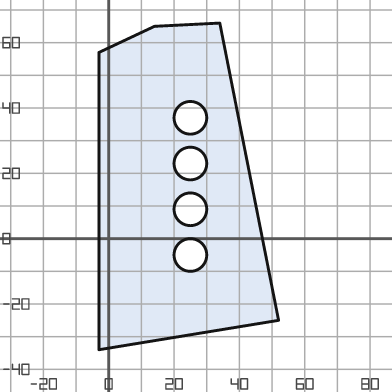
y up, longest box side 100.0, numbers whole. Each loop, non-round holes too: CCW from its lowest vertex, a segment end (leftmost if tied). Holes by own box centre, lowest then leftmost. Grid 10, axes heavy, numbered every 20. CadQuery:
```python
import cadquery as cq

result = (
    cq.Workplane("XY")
    .moveTo(-3.0, -34.0)
    .lineTo(52.0, -25.0)
    .lineTo(34.0, 66.0)
    .lineTo(14.0, 65.0)
    .lineTo(-3.0, 57.0)
    .close()
    .moveTo(25.0, -5.0)
    .circle(5.0)
    .moveTo(25.0, 9.0)
    .circle(5.0)
    .moveTo(25.0, 23.0)
    .circle(5.0)
    .moveTo(25.0, 37.0)
    .circle(5.0)
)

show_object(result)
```